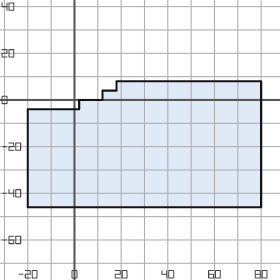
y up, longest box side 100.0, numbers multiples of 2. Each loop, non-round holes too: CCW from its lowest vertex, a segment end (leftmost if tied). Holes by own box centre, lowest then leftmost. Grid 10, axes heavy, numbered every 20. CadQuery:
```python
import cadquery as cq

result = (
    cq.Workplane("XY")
    .moveTo(-20.0, -46.0)
    .lineTo(80.0, -46.0)
    .lineTo(80.0, 8.0)
    .lineTo(18.0, 8.0)
    .lineTo(18.0, 4.0)
    .lineTo(12.0, 4.0)
    .lineTo(12.0, 0.0)
    .lineTo(2.0, 0.0)
    .lineTo(2.0, -4.0)
    .lineTo(-20.0, -4.0)
    .close()
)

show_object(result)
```